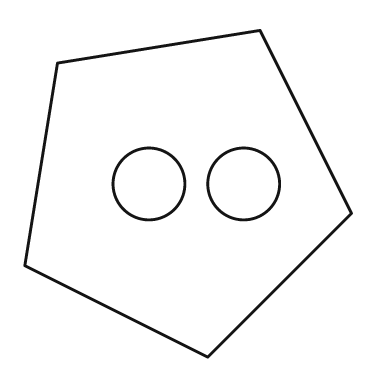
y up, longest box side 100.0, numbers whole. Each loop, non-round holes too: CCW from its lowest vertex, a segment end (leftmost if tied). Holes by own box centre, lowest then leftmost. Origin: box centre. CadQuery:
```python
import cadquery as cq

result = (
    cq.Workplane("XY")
    .moveTo(6.0, -50.0)
    .lineTo(50.0, -6.0)
    .lineTo(22.0, 50.0)
    .lineTo(-40.0, 40.0)
    .lineTo(-50.0, -22.0)
    .close()
    .moveTo(-12.0, 3.0)
    .circle(11.0)
    .moveTo(17.0, 3.0)
    .circle(11.0)
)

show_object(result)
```